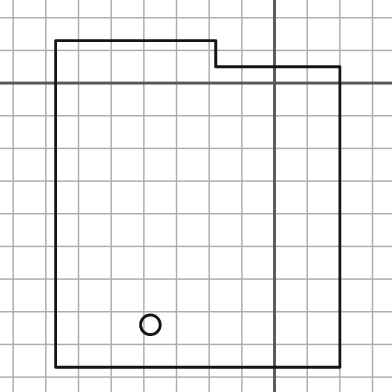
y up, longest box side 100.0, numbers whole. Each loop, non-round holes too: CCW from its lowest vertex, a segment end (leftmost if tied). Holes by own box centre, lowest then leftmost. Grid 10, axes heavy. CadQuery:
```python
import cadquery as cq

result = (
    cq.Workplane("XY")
    .moveTo(-67.0, -87.0)
    .lineTo(20.0, -87.0)
    .lineTo(20.0, 5.0)
    .lineTo(-18.0, 5.0)
    .lineTo(-18.0, 13.0)
    .lineTo(-67.0, 13.0)
    .close()
    .moveTo(-38.0, -74.0)
    .circle(3.0)
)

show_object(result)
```